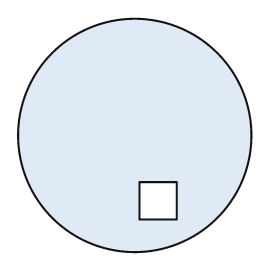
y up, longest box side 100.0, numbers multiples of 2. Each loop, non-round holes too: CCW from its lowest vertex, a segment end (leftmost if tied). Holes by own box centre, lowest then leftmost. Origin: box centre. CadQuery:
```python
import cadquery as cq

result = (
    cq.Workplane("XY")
    .moveTo(0.0, 0.0)
    .circle(50.0)
    .moveTo(2.0, -36.0)
    .lineTo(18.0, -36.0)
    .lineTo(18.0, -20.0)
    .lineTo(2.0, -20.0)
    .close()
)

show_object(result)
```